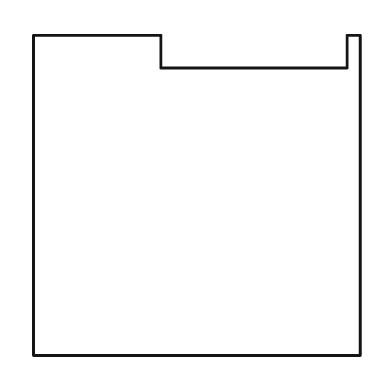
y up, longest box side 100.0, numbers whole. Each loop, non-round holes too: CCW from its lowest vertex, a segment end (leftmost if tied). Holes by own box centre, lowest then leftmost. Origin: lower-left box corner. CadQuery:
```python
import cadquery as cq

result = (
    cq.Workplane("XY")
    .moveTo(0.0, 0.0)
    .lineTo(100.0, 0.0)
    .lineTo(100.0, 98.0)
    .lineTo(96.0, 98.0)
    .lineTo(96.0, 88.0)
    .lineTo(39.0, 88.0)
    .lineTo(39.0, 98.0)
    .lineTo(0.0, 98.0)
    .close()
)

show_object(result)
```